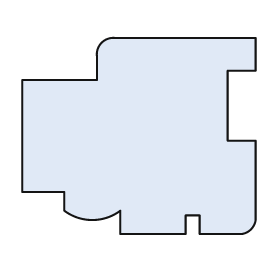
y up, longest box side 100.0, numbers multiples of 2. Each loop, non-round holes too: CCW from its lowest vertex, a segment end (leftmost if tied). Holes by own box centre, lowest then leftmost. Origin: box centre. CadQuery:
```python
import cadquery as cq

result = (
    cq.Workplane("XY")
    .moveTo(-8.0, -42.0)
    .lineTo(20.0, -42.0)
    .lineTo(20.0, -34.0)
    .lineTo(26.0, -34.0)
    .lineTo(26.0, -42.0)
    .lineTo(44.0, -42.0)
    .threePointArc((48.0, -40.0), (50.0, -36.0))
    .lineTo(50.0, -2.0)
    .lineTo(38.0, -2.0)
    .lineTo(38.0, 28.0)
    .lineTo(50.0, 28.0)
    .lineTo(50.0, 42.0)
    .lineTo(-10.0, 42.0)
    .threePointArc((-16.0, 40.0), (-18.0, 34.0))
    .lineTo(-18.0, 24.0)
    .lineTo(-50.0, 24.0)
    .lineTo(-50.0, -24.0)
    .lineTo(-32.0, -24.0)
    .lineTo(-32.0, -32.0)
    .threePointArc((-20.0, -36.0), (-8.0, -32.0))
    .close()
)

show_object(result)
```